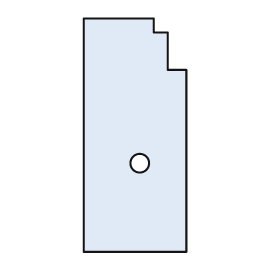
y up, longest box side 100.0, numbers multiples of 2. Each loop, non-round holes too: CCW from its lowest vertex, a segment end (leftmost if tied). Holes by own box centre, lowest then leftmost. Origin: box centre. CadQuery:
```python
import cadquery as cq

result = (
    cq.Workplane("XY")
    .moveTo(-22.0, -50.0)
    .lineTo(22.0, -50.0)
    .lineTo(22.0, 28.0)
    .lineTo(14.0, 28.0)
    .lineTo(14.0, 44.0)
    .lineTo(8.0, 44.0)
    .lineTo(8.0, 50.0)
    .lineTo(-22.0, 50.0)
    .close()
    .moveTo(2.0, -12.0)
    .circle(4.0)
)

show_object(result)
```